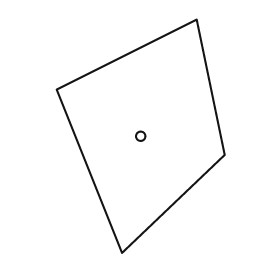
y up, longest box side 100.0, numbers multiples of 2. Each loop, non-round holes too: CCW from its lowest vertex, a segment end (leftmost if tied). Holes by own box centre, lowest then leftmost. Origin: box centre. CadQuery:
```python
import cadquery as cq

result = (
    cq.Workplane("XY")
    .moveTo(-8.0, -50.0)
    .lineTo(36.0, -8.0)
    .lineTo(24.0, 50.0)
    .lineTo(-36.0, 20.0)
    .close()
    .moveTo(0.0, 0.0)
    .circle(2.0)
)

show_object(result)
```